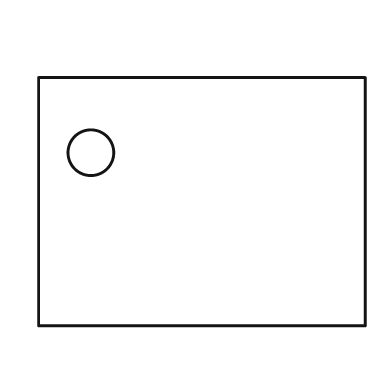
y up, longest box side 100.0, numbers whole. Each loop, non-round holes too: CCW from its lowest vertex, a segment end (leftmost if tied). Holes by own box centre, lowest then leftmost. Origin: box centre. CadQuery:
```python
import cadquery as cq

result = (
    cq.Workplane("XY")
    .moveTo(-50.0, -38.0)
    .lineTo(50.0, -38.0)
    .lineTo(50.0, 38.0)
    .lineTo(-50.0, 38.0)
    .close()
    .moveTo(-34.0, 15.0)
    .circle(7.0)
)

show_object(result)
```